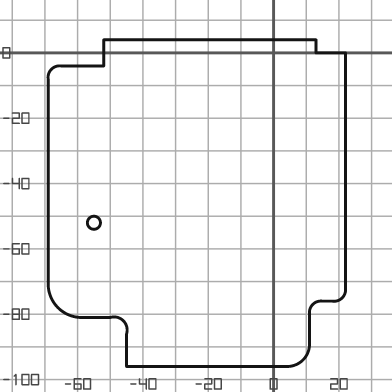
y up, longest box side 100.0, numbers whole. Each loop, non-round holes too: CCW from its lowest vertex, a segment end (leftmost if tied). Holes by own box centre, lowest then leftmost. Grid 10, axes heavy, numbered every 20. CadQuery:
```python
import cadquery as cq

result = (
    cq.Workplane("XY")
    .moveTo(-45.0, -96.0)
    .lineTo(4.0, -96.0)
    .threePointArc((9.0, -94.0), (11.0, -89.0))
    .lineTo(11.0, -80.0)
    .threePointArc((12.0, -77.0), (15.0, -76.0))
    .lineTo(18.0, -76.0)
    .threePointArc((21.0, -75.0), (22.0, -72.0))
    .lineTo(22.0, 0.0)
    .lineTo(13.0, 0.0)
    .lineTo(13.0, 4.0)
    .lineTo(-52.0, 4.0)
    .lineTo(-52.0, -4.0)
    .lineTo(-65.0, -4.0)
    .threePointArc((-68.0, -5.0), (-69.0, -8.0))
    .lineTo(-69.0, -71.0)
    .threePointArc((-66.0, -78.0), (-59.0, -81.0))
    .lineTo(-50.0, -81.0)
    .threePointArc((-46.0, -82.0), (-45.0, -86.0))
    .close()
    .moveTo(-55.0, -52.0)
    .circle(2.0)
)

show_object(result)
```